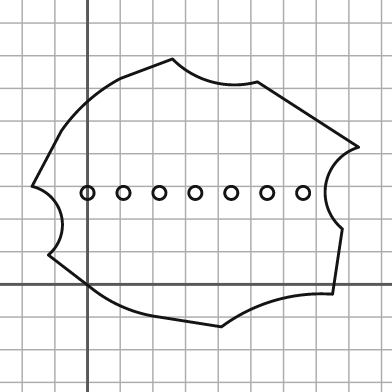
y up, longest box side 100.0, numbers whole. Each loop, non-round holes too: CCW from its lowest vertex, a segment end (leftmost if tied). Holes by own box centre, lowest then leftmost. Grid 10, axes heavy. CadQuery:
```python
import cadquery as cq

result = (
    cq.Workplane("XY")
    .moveTo(41.0, -13.0)
    .threePointArc((57.0, -5.0), (75.0, -3.0))
    .lineTo(78.0, 17.0)
    .threePointArc((73.0, 31.0), (83.0, 42.0))
    .lineTo(52.0, 62.0)
    .threePointArc((38.0, 62.0), (26.0, 69.0))
    .lineTo(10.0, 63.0)
    .threePointArc((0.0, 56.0), (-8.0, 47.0))
    .lineTo(-17.0, 30.0)
    .threePointArc((-8.0, 21.0), (-12.0, 9.0))
    .lineTo(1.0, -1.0)
    .threePointArc((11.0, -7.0), (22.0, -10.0))
    .close()
    .moveTo(0.0, 28.0)
    .circle(2.0)
    .moveTo(11.0, 28.0)
    .circle(2.0)
    .moveTo(22.0, 28.0)
    .circle(2.0)
    .moveTo(33.0, 28.0)
    .circle(2.0)
    .moveTo(44.0, 28.0)
    .circle(2.0)
    .moveTo(55.0, 28.0)
    .circle(2.0)
    .moveTo(66.0, 28.0)
    .circle(2.0)
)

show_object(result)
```